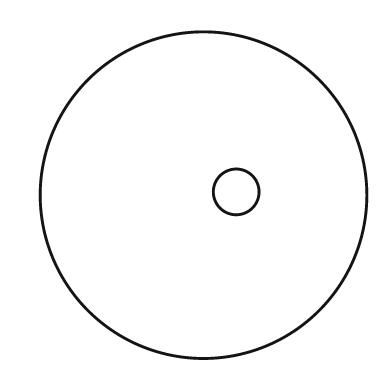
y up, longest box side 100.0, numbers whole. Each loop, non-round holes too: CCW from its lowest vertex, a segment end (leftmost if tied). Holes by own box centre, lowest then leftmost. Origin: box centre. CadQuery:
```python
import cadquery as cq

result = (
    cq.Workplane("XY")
    .moveTo(0.0, 0.0)
    .circle(50.0)
    .moveTo(10.0, 1.0)
    .circle(7.0)
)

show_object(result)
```